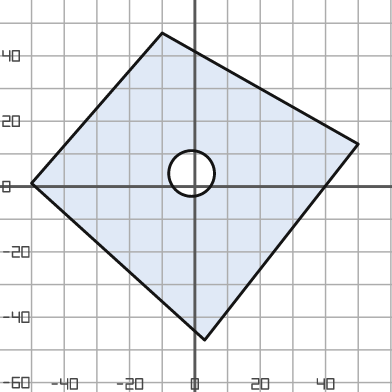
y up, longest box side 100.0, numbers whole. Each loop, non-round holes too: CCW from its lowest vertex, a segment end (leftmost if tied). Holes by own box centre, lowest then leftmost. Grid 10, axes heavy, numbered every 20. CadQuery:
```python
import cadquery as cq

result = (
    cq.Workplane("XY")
    .moveTo(3.0, -47.0)
    .lineTo(50.0, 13.0)
    .lineTo(-10.0, 47.0)
    .lineTo(-50.0, 1.0)
    .close()
    .moveTo(-1.0, 4.0)
    .circle(7.0)
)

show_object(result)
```